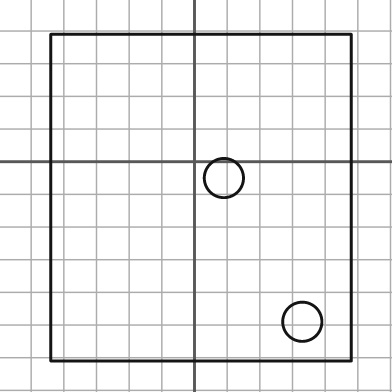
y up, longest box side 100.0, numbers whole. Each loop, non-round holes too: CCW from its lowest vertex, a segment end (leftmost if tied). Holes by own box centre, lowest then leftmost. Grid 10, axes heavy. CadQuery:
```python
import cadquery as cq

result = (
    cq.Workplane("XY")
    .moveTo(-44.0, -61.0)
    .lineTo(48.0, -61.0)
    .lineTo(48.0, 39.0)
    .lineTo(-44.0, 39.0)
    .close()
    .moveTo(33.0, -49.0)
    .circle(6.0)
    .moveTo(9.0, -5.0)
    .circle(6.0)
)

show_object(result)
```